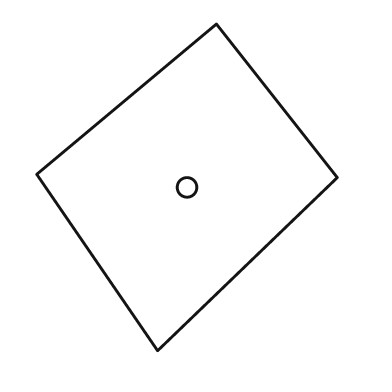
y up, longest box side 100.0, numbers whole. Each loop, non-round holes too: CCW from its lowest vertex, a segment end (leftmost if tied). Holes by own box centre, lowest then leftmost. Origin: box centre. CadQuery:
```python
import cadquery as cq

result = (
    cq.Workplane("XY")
    .moveTo(-9.0, -50.0)
    .lineTo(46.0, 3.0)
    .lineTo(9.0, 50.0)
    .lineTo(-46.0, 4.0)
    .close()
    .moveTo(0.0, 0.0)
    .circle(3.0)
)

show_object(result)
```